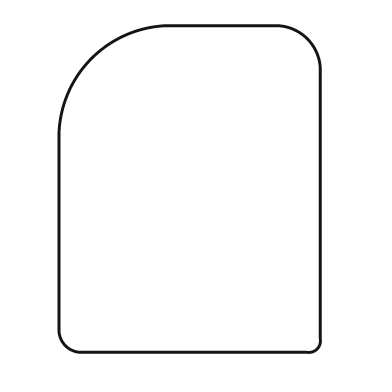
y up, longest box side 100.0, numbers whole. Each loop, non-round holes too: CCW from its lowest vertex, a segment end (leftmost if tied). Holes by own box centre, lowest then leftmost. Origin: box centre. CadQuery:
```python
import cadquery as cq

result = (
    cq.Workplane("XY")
    .moveTo(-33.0, -50.0)
    .lineTo(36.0, -50.0)
    .threePointArc((39.0, -49.0), (40.0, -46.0))
    .lineTo(40.0, 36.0)
    .threePointArc((36.0, 46.0), (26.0, 50.0))
    .lineTo(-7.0, 50.0)
    .threePointArc((-30.0, 40.0), (-40.0, 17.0))
    .lineTo(-40.0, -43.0)
    .threePointArc((-38.0, -48.0), (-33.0, -50.0))
    .close()
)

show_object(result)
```